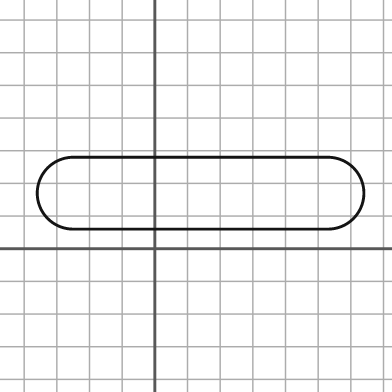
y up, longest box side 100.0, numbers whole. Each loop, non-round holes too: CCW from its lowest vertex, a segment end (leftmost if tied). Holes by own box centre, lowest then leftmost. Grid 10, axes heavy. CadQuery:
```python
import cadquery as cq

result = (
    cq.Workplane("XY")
    .moveTo(-25.0, 6.0)
    .lineTo(53.0, 6.0)
    .threePointArc((64.0, 17.0), (53.0, 28.0))
    .lineTo(-25.0, 28.0)
    .threePointArc((-36.0, 17.0), (-25.0, 6.0))
    .close()
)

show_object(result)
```